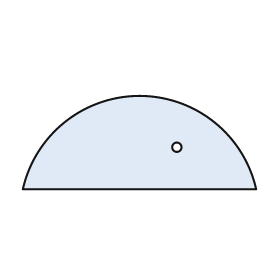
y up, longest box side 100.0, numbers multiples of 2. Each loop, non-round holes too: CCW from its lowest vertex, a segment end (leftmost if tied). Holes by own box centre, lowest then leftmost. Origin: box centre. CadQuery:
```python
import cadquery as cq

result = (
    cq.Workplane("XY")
    .moveTo(-50.0, -20.0)
    .lineTo(50.0, -20.0)
    .threePointArc((0.0, 20.0), (-50.0, -20.0))
    .close()
    .moveTo(16.0, -2.0)
    .circle(2.0)
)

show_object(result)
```